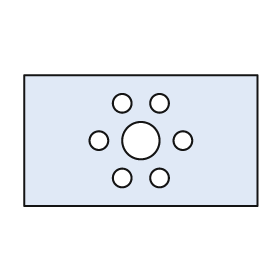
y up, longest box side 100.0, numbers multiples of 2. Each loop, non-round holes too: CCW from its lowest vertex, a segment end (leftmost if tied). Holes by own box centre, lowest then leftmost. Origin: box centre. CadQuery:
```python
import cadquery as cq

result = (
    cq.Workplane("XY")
    .moveTo(-50.0, -28.0)
    .lineTo(50.0, -28.0)
    .lineTo(50.0, 28.0)
    .lineTo(-50.0, 28.0)
    .close()
    .moveTo(-8.0, -16.0)
    .circle(4.0)
    .moveTo(8.0, -16.0)
    .circle(4.0)
    .moveTo(-18.0, 0.0)
    .circle(4.0)
    .moveTo(0.0, 0.0)
    .circle(8.0)
    .moveTo(18.0, 0.0)
    .circle(4.0)
    .moveTo(-8.0, 16.0)
    .circle(4.0)
    .moveTo(8.0, 16.0)
    .circle(4.0)
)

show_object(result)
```